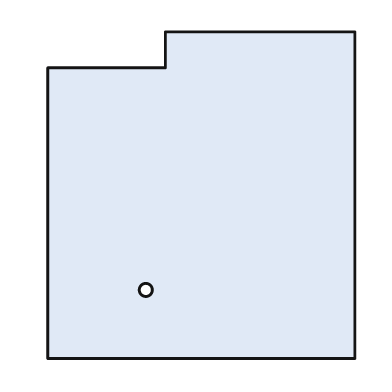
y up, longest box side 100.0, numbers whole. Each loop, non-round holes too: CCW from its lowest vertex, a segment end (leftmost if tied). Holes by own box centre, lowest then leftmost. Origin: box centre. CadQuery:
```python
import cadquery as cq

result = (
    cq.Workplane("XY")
    .moveTo(-47.0, -50.0)
    .lineTo(47.0, -50.0)
    .lineTo(47.0, 50.0)
    .lineTo(-11.0, 50.0)
    .lineTo(-11.0, 39.0)
    .lineTo(-47.0, 39.0)
    .close()
    .moveTo(-17.0, -29.0)
    .circle(2.0)
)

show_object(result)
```